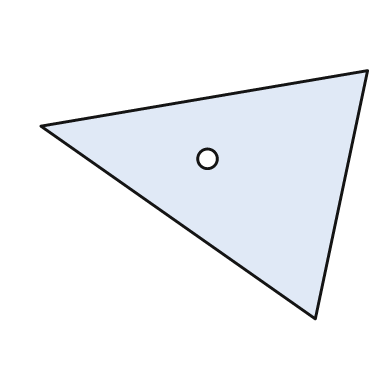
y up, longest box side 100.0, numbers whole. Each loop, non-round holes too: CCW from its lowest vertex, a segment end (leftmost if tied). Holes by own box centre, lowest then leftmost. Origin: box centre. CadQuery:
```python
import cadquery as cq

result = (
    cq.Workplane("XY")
    .moveTo(34.0, -38.0)
    .lineTo(50.0, 38.0)
    .lineTo(-50.0, 21.0)
    .close()
    .moveTo(1.0, 11.0)
    .circle(3.0)
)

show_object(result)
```